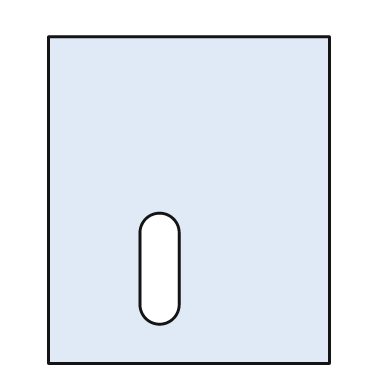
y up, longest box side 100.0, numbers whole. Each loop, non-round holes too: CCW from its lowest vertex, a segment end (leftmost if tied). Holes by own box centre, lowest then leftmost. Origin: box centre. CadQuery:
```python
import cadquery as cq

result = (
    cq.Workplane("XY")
    .moveTo(-43.0, -50.0)
    .lineTo(43.0, -50.0)
    .lineTo(43.0, 50.0)
    .lineTo(-43.0, 50.0)
    .close()
    .moveTo(-15.0, -32.0)
    .threePointArc((-9.0, -38.0), (-3.0, -32.0))
    .lineTo(-3.0, -10.0)
    .threePointArc((-9.0, -4.0), (-15.0, -10.0))
    .close()
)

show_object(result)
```